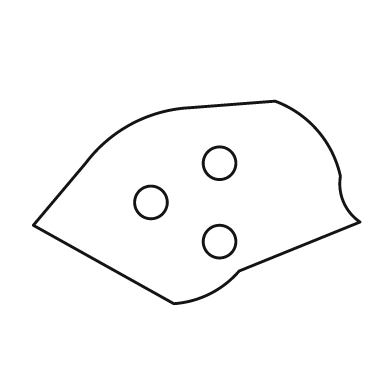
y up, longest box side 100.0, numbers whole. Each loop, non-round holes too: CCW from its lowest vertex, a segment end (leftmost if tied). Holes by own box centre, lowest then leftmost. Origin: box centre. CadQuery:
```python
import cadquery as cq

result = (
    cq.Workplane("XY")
    .moveTo(-7.0, -31.0)
    .threePointArc((4.0, -28.0), (13.0, -21.0))
    .lineTo(50.0, -6.0)
    .threePointArc((45.0, 0.0), (44.0, 8.0))
    .threePointArc((37.0, 22.0), (24.0, 31.0))
    .lineTo(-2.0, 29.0)
    .threePointArc((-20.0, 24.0), (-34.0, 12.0))
    .lineTo(-50.0, -7.0)
    .close()
    .moveTo(7.0, -12.0)
    .circle(5.0)
    .moveTo(-14.0, 0.0)
    .circle(5.0)
    .moveTo(7.0, 12.0)
    .circle(5.0)
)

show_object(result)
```